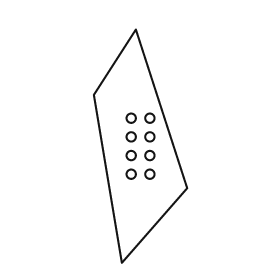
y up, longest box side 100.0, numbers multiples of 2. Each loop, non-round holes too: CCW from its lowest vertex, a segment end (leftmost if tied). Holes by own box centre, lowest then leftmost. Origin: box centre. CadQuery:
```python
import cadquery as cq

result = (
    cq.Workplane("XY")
    .moveTo(-8.0, -50.0)
    .lineTo(20.0, -18.0)
    .lineTo(-2.0, 50.0)
    .lineTo(-20.0, 22.0)
    .close()
    .moveTo(-4.0, -12.0)
    .circle(2.0)
    .moveTo(4.0, -12.0)
    .circle(2.0)
    .moveTo(-4.0, -4.0)
    .circle(2.0)
    .moveTo(4.0, -4.0)
    .circle(2.0)
    .moveTo(-4.0, 4.0)
    .circle(2.0)
    .moveTo(4.0, 4.0)
    .circle(2.0)
    .moveTo(-4.0, 12.0)
    .circle(2.0)
    .moveTo(4.0, 12.0)
    .circle(2.0)
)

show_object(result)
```